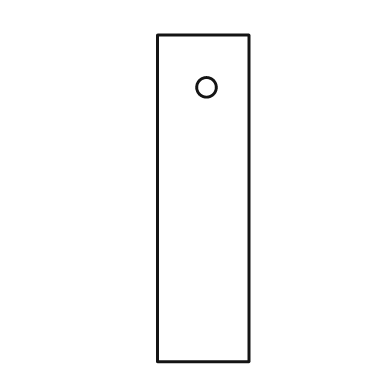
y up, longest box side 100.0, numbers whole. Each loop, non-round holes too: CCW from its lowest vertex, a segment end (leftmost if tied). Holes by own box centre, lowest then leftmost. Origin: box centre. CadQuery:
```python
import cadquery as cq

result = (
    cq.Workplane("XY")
    .moveTo(-14.0, -50.0)
    .lineTo(14.0, -50.0)
    .lineTo(14.0, 50.0)
    .lineTo(-14.0, 50.0)
    .close()
    .moveTo(1.0, 34.0)
    .circle(3.0)
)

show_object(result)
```